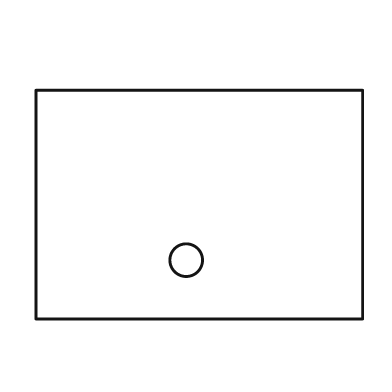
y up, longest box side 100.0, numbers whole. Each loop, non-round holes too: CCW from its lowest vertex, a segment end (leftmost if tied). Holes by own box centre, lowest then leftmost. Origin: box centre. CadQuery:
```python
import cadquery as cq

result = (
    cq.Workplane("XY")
    .moveTo(-50.0, -35.0)
    .lineTo(50.0, -35.0)
    .lineTo(50.0, 35.0)
    .lineTo(-50.0, 35.0)
    .close()
    .moveTo(-4.0, -17.0)
    .circle(5.0)
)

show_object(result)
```